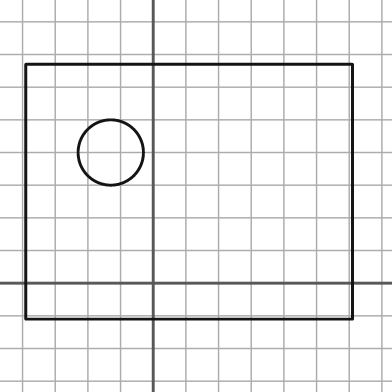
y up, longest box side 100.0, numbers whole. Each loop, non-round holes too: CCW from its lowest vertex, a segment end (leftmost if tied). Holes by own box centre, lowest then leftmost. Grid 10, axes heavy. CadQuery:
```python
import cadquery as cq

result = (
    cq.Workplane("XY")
    .moveTo(-39.0, -11.0)
    .lineTo(61.0, -11.0)
    .lineTo(61.0, 67.0)
    .lineTo(-39.0, 67.0)
    .close()
    .moveTo(-13.0, 40.0)
    .circle(10.0)
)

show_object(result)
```